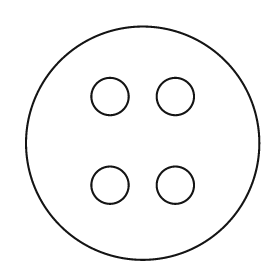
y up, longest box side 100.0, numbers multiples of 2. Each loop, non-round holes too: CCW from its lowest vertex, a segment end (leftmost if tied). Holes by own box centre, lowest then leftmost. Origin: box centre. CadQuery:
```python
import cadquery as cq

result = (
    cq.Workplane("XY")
    .moveTo(0.0, 0.0)
    .circle(50.0)
    .moveTo(-14.0, -18.0)
    .circle(8.0)
    .moveTo(14.0, -18.0)
    .circle(8.0)
    .moveTo(-14.0, 20.0)
    .circle(8.0)
    .moveTo(14.0, 20.0)
    .circle(8.0)
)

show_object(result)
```